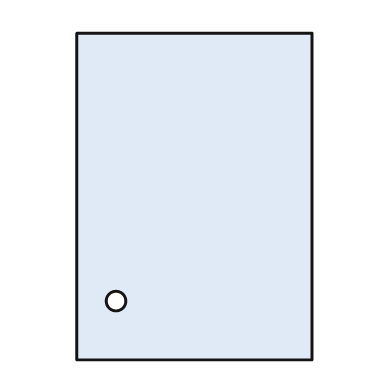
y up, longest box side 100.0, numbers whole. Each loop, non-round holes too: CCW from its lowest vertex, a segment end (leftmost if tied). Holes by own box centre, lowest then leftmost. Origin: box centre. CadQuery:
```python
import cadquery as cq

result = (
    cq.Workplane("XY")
    .moveTo(-36.0, -50.0)
    .lineTo(36.0, -50.0)
    .lineTo(36.0, 50.0)
    .lineTo(-36.0, 50.0)
    .close()
    .moveTo(-24.0, -32.0)
    .circle(3.0)
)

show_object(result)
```